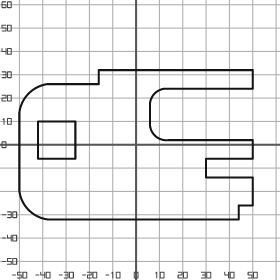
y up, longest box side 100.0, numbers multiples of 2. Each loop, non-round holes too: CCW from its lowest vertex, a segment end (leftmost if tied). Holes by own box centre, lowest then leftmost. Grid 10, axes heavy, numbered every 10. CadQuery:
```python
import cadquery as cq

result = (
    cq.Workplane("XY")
    .moveTo(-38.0, -32.0)
    .lineTo(44.0, -32.0)
    .lineTo(44.0, -26.0)
    .lineTo(50.0, -26.0)
    .lineTo(50.0, -14.0)
    .lineTo(30.0, -14.0)
    .lineTo(30.0, -6.0)
    .lineTo(50.0, -6.0)
    .lineTo(50.0, 2.0)
    .lineTo(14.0, 2.0)
    .threePointArc((8.0, 4.0), (6.0, 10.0))
    .lineTo(6.0, 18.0)
    .threePointArc((8.0, 22.0), (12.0, 24.0))
    .lineTo(50.0, 24.0)
    .lineTo(50.0, 32.0)
    .lineTo(-16.0, 32.0)
    .lineTo(-16.0, 26.0)
    .lineTo(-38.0, 26.0)
    .threePointArc((-46.0, 22.0), (-50.0, 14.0))
    .lineTo(-50.0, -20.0)
    .threePointArc((-46.0, -28.0), (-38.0, -32.0))
    .close()
    .moveTo(-42.0, -6.0)
    .lineTo(-26.0, -6.0)
    .lineTo(-26.0, 10.0)
    .lineTo(-42.0, 10.0)
    .close()
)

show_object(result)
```